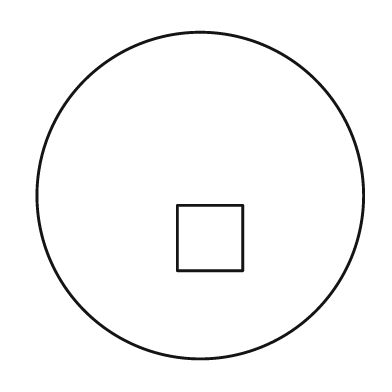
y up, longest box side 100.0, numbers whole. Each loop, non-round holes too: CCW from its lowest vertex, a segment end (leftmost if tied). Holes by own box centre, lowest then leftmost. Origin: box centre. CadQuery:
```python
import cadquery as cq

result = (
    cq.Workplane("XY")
    .moveTo(0.0, 0.0)
    .circle(50.0)
    .moveTo(-7.0, -23.0)
    .lineTo(13.0, -23.0)
    .lineTo(13.0, -3.0)
    .lineTo(-7.0, -3.0)
    .close()
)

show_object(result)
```